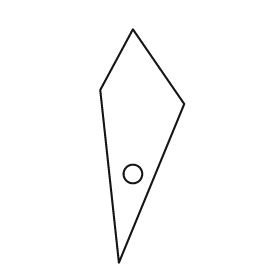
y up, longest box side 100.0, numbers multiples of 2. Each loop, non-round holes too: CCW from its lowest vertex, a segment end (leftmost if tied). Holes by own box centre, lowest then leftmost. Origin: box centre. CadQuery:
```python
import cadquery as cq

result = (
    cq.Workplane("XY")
    .moveTo(-10.0, -50.0)
    .lineTo(18.0, 18.0)
    .lineTo(-4.0, 50.0)
    .lineTo(-18.0, 24.0)
    .close()
    .moveTo(-4.0, -12.0)
    .circle(4.0)
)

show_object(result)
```